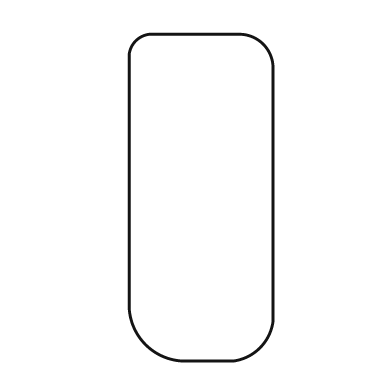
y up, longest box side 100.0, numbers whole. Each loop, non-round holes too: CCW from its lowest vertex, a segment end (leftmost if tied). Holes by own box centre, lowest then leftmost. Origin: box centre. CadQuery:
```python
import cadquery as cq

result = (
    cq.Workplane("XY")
    .moveTo(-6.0, -50.0)
    .lineTo(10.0, -50.0)
    .threePointArc((18.0, -46.0), (22.0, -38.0))
    .lineTo(22.0, 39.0)
    .threePointArc((19.0, 47.0), (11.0, 50.0))
    .lineTo(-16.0, 50.0)
    .threePointArc((-20.0, 48.0), (-22.0, 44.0))
    .lineTo(-22.0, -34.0)
    .threePointArc((-17.0, -45.0), (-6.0, -50.0))
    .close()
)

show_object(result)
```